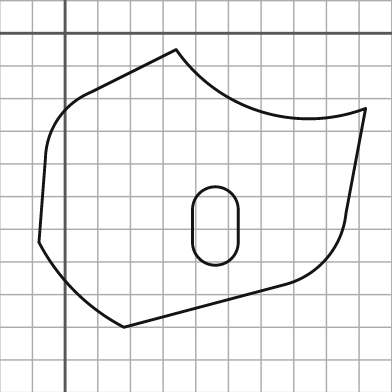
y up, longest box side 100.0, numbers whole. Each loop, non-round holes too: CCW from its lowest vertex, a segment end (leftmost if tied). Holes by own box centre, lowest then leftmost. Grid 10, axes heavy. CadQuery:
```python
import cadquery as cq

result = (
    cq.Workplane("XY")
    .moveTo(18.0, -90.0)
    .lineTo(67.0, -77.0)
    .threePointArc((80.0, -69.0), (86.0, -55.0))
    .lineTo(92.0, -23.0)
    .threePointArc((60.0, -24.0), (34.0, -5.0))
    .lineTo(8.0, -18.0)
    .threePointArc((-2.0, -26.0), (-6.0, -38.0))
    .lineTo(-8.0, -64.0)
    .threePointArc((3.0, -79.0), (18.0, -90.0))
    .close()
    .moveTo(39.0, -64.0)
    .threePointArc((46.0, -71.0), (53.0, -64.0))
    .lineTo(53.0, -54.0)
    .threePointArc((46.0, -47.0), (39.0, -54.0))
    .close()
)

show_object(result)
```